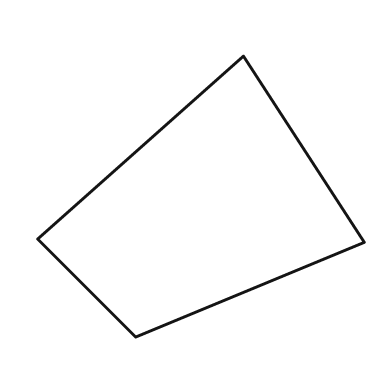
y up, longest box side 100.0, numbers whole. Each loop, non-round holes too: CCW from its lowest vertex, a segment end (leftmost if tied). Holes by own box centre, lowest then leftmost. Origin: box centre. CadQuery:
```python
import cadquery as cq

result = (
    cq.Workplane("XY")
    .moveTo(-20.0, -43.0)
    .lineTo(50.0, -14.0)
    .lineTo(13.0, 43.0)
    .lineTo(-50.0, -13.0)
    .close()
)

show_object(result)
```